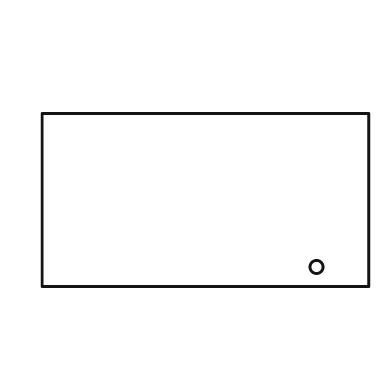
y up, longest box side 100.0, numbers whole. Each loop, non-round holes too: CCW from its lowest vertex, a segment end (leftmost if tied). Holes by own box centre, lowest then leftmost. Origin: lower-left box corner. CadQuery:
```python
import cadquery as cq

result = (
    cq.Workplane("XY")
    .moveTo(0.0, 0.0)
    .lineTo(100.0, 0.0)
    .lineTo(100.0, 53.0)
    .lineTo(0.0, 53.0)
    .close()
    .moveTo(84.0, 6.0)
    .circle(2.0)
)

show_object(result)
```